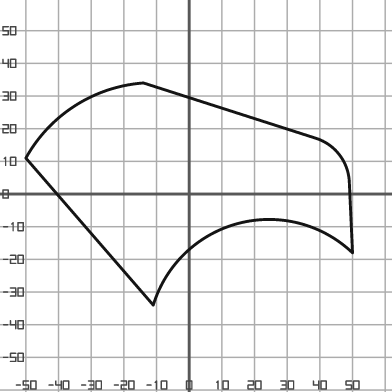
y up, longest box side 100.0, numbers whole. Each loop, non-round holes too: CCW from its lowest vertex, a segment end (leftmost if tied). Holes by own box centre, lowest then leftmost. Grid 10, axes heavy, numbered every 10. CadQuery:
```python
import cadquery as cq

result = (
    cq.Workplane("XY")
    .moveTo(-11.0, -34.0)
    .threePointArc((15.0, -9.0), (50.0, -18.0))
    .lineTo(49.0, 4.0)
    .threePointArc((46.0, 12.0), (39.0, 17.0))
    .lineTo(-14.0, 34.0)
    .threePointArc((-35.0, 27.0), (-50.0, 11.0))
    .close()
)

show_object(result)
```